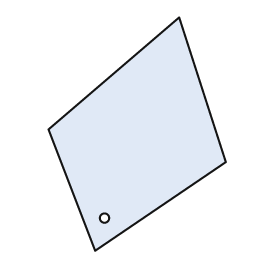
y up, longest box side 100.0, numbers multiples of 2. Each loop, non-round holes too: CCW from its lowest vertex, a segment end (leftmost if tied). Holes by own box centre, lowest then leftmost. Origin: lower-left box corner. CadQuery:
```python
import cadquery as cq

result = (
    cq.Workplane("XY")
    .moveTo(20.0, 0.0)
    .lineTo(76.0, 38.0)
    .lineTo(56.0, 100.0)
    .lineTo(0.0, 52.0)
    .close()
    .moveTo(24.0, 14.0)
    .circle(2.0)
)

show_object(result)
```